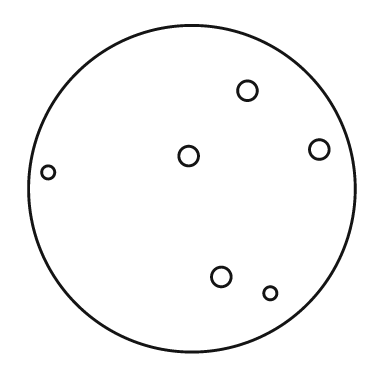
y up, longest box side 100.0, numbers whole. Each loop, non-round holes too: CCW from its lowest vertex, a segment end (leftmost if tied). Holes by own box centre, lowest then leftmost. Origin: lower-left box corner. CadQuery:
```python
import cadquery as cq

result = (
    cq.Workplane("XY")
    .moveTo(50.0, 50.0)
    .circle(50.0)
    .moveTo(74.0, 18.0)
    .circle(2.0)
    .moveTo(59.0, 23.0)
    .circle(3.0)
    .moveTo(6.0, 55.0)
    .circle(2.0)
    .moveTo(49.0, 60.0)
    .circle(3.0)
    .moveTo(89.0, 62.0)
    .circle(3.0)
    .moveTo(67.0, 80.0)
    .circle(3.0)
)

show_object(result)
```